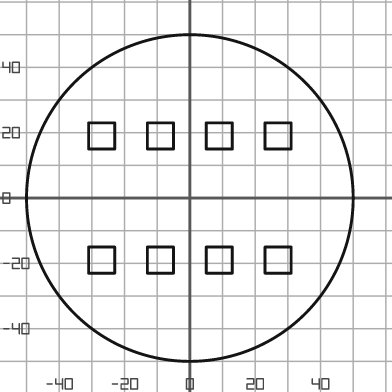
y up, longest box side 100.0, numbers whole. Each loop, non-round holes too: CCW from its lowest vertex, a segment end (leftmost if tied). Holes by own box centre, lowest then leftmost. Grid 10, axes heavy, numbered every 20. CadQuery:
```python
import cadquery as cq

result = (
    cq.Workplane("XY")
    .moveTo(0.0, 0.0)
    .circle(50.0)
    .moveTo(-31.0, -23.0)
    .lineTo(-23.0, -23.0)
    .lineTo(-23.0, -15.0)
    .lineTo(-31.0, -15.0)
    .close()
    .moveTo(-13.0, -23.0)
    .lineTo(-5.0, -23.0)
    .lineTo(-5.0, -15.0)
    .lineTo(-13.0, -15.0)
    .close()
    .moveTo(5.0, -23.0)
    .lineTo(13.0, -23.0)
    .lineTo(13.0, -15.0)
    .lineTo(5.0, -15.0)
    .close()
    .moveTo(23.0, -23.0)
    .lineTo(31.0, -23.0)
    .lineTo(31.0, -15.0)
    .lineTo(23.0, -15.0)
    .close()
    .moveTo(-31.0, 15.0)
    .lineTo(-23.0, 15.0)
    .lineTo(-23.0, 23.0)
    .lineTo(-31.0, 23.0)
    .close()
    .moveTo(-13.0, 15.0)
    .lineTo(-5.0, 15.0)
    .lineTo(-5.0, 23.0)
    .lineTo(-13.0, 23.0)
    .close()
    .moveTo(5.0, 15.0)
    .lineTo(13.0, 15.0)
    .lineTo(13.0, 23.0)
    .lineTo(5.0, 23.0)
    .close()
    .moveTo(23.0, 15.0)
    .lineTo(31.0, 15.0)
    .lineTo(31.0, 23.0)
    .lineTo(23.0, 23.0)
    .close()
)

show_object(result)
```